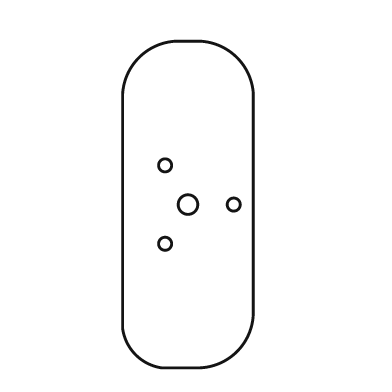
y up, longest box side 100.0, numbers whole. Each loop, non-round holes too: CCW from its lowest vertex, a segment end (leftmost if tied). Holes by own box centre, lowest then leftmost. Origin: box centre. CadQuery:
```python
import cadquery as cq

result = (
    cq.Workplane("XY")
    .moveTo(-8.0, -50.0)
    .lineTo(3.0, -50.0)
    .threePointArc((15.0, -45.0), (20.0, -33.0))
    .lineTo(20.0, 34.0)
    .threePointArc((15.0, 45.0), (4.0, 50.0))
    .lineTo(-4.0, 50.0)
    .threePointArc((-15.0, 45.0), (-20.0, 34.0))
    .lineTo(-20.0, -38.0)
    .threePointArc((-16.0, -46.0), (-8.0, -50.0))
    .close()
    .moveTo(-7.0, -12.0)
    .circle(2.0)
    .moveTo(0.0, 0.0)
    .circle(3.0)
    .moveTo(14.0, 0.0)
    .circle(2.0)
    .moveTo(-7.0, 12.0)
    .circle(2.0)
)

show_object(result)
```